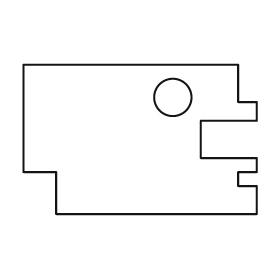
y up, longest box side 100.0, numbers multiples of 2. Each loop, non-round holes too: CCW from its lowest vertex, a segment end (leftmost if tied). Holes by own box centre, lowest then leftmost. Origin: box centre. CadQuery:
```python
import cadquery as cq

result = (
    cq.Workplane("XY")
    .moveTo(-36.0, -32.0)
    .lineTo(50.0, -32.0)
    .lineTo(50.0, -20.0)
    .lineTo(42.0, -20.0)
    .lineTo(42.0, -14.0)
    .lineTo(50.0, -14.0)
    .lineTo(50.0, -8.0)
    .lineTo(26.0, -8.0)
    .lineTo(26.0, 8.0)
    .lineTo(50.0, 8.0)
    .lineTo(50.0, 16.0)
    .lineTo(42.0, 16.0)
    .lineTo(42.0, 32.0)
    .lineTo(-50.0, 32.0)
    .lineTo(-50.0, -14.0)
    .lineTo(-36.0, -14.0)
    .close()
    .moveTo(14.0, 18.0)
    .circle(8.0)
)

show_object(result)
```